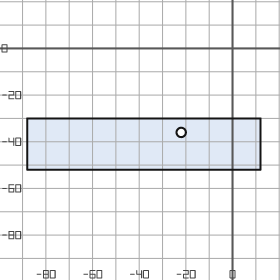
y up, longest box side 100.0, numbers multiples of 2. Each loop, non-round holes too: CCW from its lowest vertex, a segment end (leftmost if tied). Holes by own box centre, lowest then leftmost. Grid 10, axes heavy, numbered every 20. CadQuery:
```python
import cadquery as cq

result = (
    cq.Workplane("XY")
    .moveTo(-88.0, -52.0)
    .lineTo(12.0, -52.0)
    .lineTo(12.0, -30.0)
    .lineTo(-88.0, -30.0)
    .close()
    .moveTo(-22.0, -36.0)
    .circle(2.0)
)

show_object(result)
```